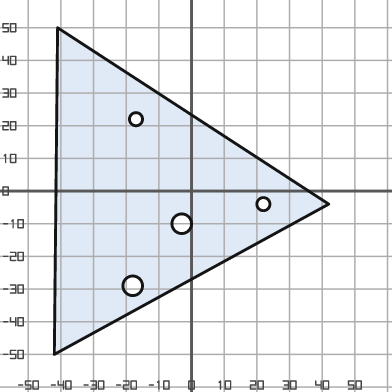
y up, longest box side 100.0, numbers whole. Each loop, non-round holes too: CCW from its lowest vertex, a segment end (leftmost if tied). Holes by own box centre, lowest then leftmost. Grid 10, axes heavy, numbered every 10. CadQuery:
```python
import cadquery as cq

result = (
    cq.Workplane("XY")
    .moveTo(-42.0, -50.0)
    .lineTo(42.0, -4.0)
    .lineTo(-41.0, 50.0)
    .close()
    .moveTo(-18.0, -29.0)
    .circle(3.0)
    .moveTo(-3.0, -10.0)
    .circle(3.0)
    .moveTo(22.0, -4.0)
    .circle(2.0)
    .moveTo(-17.0, 22.0)
    .circle(2.0)
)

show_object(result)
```